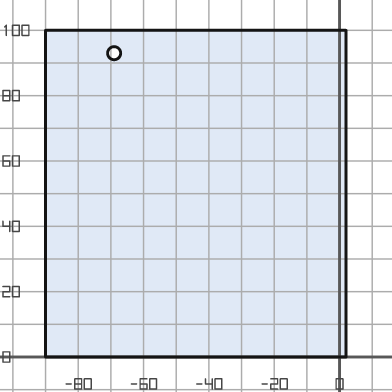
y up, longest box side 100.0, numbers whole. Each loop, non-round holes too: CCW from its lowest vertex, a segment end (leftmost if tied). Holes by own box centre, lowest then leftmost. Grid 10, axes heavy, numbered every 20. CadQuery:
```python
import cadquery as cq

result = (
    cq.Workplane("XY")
    .moveTo(-90.0, 0.0)
    .lineTo(2.0, 0.0)
    .lineTo(2.0, 100.0)
    .lineTo(-90.0, 100.0)
    .close()
    .moveTo(-69.0, 93.0)
    .circle(2.0)
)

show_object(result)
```